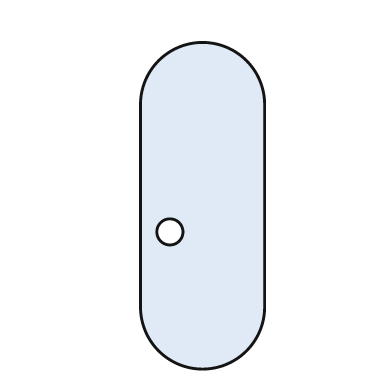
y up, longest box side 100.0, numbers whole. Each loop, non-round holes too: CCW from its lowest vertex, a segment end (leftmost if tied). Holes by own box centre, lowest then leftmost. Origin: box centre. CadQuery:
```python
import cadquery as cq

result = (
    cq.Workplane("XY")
    .moveTo(-19.0, -31.0)
    .threePointArc((0.0, -50.0), (19.0, -31.0))
    .lineTo(19.0, 31.0)
    .threePointArc((0.0, 50.0), (-19.0, 31.0))
    .close()
    .moveTo(-10.0, -8.0)
    .circle(4.0)
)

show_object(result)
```